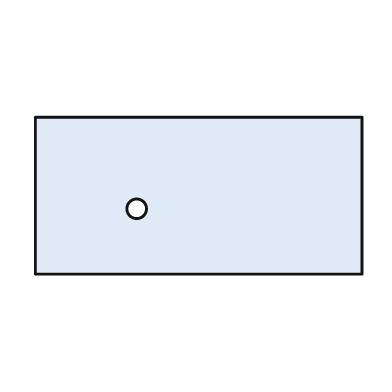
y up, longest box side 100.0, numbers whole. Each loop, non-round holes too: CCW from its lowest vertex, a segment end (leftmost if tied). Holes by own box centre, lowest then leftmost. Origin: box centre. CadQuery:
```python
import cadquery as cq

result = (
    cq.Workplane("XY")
    .moveTo(-50.0, -24.0)
    .lineTo(50.0, -24.0)
    .lineTo(50.0, 24.0)
    .lineTo(-50.0, 24.0)
    .close()
    .moveTo(-19.0, -4.0)
    .circle(3.0)
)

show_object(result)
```